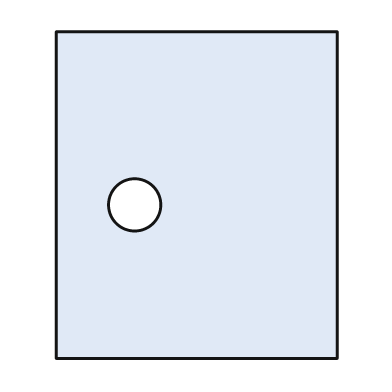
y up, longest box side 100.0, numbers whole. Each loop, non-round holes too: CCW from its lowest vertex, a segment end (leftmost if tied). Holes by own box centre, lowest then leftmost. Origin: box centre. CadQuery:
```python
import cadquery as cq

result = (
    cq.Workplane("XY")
    .moveTo(-43.0, -50.0)
    .lineTo(43.0, -50.0)
    .lineTo(43.0, 50.0)
    .lineTo(-43.0, 50.0)
    .close()
    .moveTo(-19.0, -3.0)
    .circle(8.0)
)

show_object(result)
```